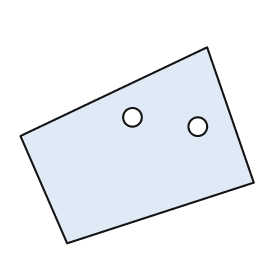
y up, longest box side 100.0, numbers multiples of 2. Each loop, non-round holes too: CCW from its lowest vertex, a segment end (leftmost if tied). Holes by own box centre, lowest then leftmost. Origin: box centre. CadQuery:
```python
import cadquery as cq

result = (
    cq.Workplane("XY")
    .moveTo(-30.0, -42.0)
    .lineTo(50.0, -16.0)
    .lineTo(30.0, 42.0)
    .lineTo(-50.0, 4.0)
    .close()
    .moveTo(26.0, 8.0)
    .circle(4.0)
    .moveTo(-2.0, 12.0)
    .circle(4.0)
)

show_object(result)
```